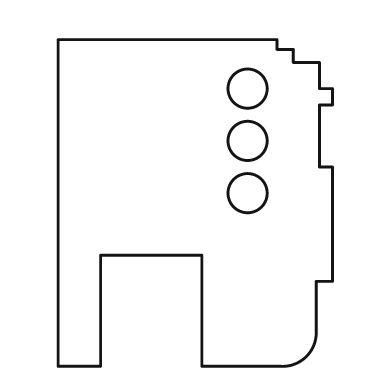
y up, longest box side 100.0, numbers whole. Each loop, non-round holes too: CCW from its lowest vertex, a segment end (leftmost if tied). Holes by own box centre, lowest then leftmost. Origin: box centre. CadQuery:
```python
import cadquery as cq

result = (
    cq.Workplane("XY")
    .moveTo(-42.0, -50.0)
    .lineTo(-29.0, -50.0)
    .lineTo(-29.0, -16.0)
    .lineTo(2.0, -16.0)
    .lineTo(2.0, -50.0)
    .lineTo(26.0, -50.0)
    .threePointArc((34.0, -47.0), (37.0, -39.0))
    .lineTo(37.0, -24.0)
    .lineTo(42.0, -24.0)
    .lineTo(42.0, 11.0)
    .lineTo(38.0, 11.0)
    .lineTo(38.0, 30.0)
    .lineTo(42.0, 30.0)
    .lineTo(42.0, 35.0)
    .lineTo(38.0, 35.0)
    .lineTo(38.0, 43.0)
    .lineTo(30.0, 43.0)
    .lineTo(30.0, 47.0)
    .lineTo(25.0, 47.0)
    .lineTo(25.0, 50.0)
    .lineTo(-42.0, 50.0)
    .close()
    .moveTo(16.0, 3.0)
    .circle(6.0)
    .moveTo(16.0, 19.0)
    .circle(6.0)
    .moveTo(16.0, 35.0)
    .circle(6.0)
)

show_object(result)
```